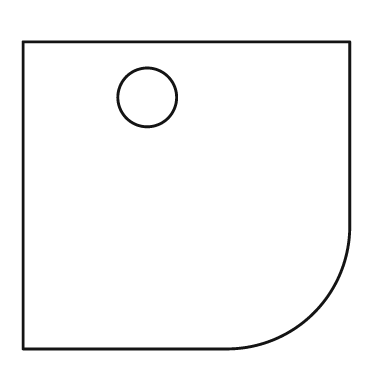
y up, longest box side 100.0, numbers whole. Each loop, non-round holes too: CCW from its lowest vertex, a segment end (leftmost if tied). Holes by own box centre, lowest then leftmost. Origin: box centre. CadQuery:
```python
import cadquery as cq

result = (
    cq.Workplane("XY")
    .moveTo(-50.0, -47.0)
    .lineTo(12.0, -47.0)
    .threePointArc((39.0, -36.0), (50.0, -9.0))
    .lineTo(50.0, 47.0)
    .lineTo(-50.0, 47.0)
    .close()
    .moveTo(-12.0, 30.0)
    .circle(9.0)
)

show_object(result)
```